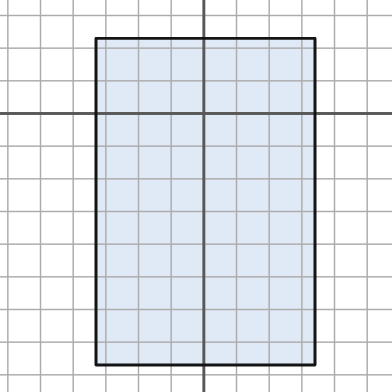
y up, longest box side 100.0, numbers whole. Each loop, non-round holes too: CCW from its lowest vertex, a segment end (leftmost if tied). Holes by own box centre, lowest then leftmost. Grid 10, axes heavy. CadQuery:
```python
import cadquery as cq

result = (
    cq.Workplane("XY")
    .moveTo(-33.0, -77.0)
    .lineTo(34.0, -77.0)
    .lineTo(34.0, 23.0)
    .lineTo(-33.0, 23.0)
    .close()
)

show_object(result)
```